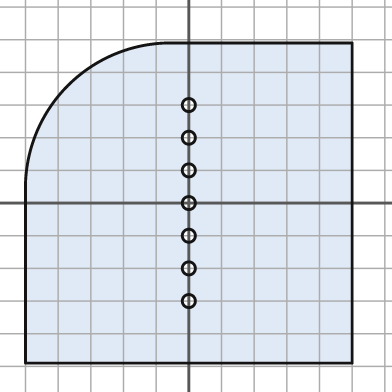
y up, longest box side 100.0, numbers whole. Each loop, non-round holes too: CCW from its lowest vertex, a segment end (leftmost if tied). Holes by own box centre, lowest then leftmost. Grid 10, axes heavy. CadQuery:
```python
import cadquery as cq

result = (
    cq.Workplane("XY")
    .moveTo(-50.0, -49.0)
    .lineTo(50.0, -49.0)
    .lineTo(50.0, 49.0)
    .lineTo(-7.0, 49.0)
    .threePointArc((-37.0, 36.0), (-50.0, 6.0))
    .close()
    .moveTo(0.0, -30.0)
    .circle(2.0)
    .moveTo(0.0, -20.0)
    .circle(2.0)
    .moveTo(0.0, -10.0)
    .circle(2.0)
    .moveTo(0.0, 0.0)
    .circle(2.0)
    .moveTo(0.0, 10.0)
    .circle(2.0)
    .moveTo(0.0, 20.0)
    .circle(2.0)
    .moveTo(0.0, 30.0)
    .circle(2.0)
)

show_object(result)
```